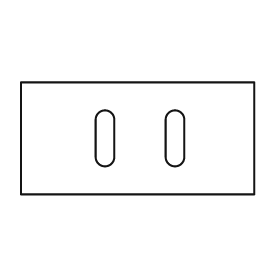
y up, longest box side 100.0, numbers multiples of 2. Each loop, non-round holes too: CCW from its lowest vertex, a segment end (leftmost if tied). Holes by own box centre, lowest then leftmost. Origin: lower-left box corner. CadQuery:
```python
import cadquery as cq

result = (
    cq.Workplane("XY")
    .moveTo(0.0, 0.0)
    .lineTo(100.0, 0.0)
    .lineTo(100.0, 48.0)
    .lineTo(0.0, 48.0)
    .close()
    .moveTo(32.0, 16.0)
    .threePointArc((36.0, 12.0), (40.0, 16.0))
    .lineTo(40.0, 32.0)
    .threePointArc((36.0, 36.0), (32.0, 32.0))
    .close()
    .moveTo(62.0, 16.0)
    .threePointArc((66.0, 12.0), (70.0, 16.0))
    .lineTo(70.0, 32.0)
    .threePointArc((66.0, 36.0), (62.0, 32.0))
    .close()
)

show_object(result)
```